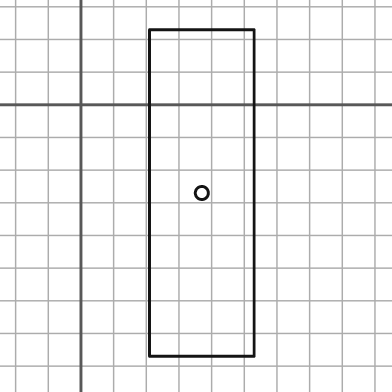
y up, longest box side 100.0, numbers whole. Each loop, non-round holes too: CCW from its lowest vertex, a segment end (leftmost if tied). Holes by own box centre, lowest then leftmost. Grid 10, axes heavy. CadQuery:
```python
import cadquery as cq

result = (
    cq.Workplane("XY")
    .moveTo(21.0, -77.0)
    .lineTo(53.0, -77.0)
    .lineTo(53.0, 23.0)
    .lineTo(21.0, 23.0)
    .close()
    .moveTo(37.0, -27.0)
    .circle(2.0)
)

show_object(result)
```